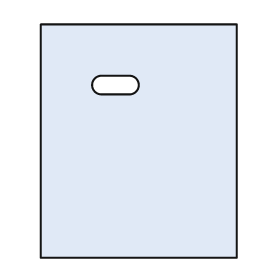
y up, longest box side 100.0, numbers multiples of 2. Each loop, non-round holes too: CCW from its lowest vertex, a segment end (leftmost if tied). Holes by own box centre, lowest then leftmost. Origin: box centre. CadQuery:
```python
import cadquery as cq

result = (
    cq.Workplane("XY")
    .moveTo(-42.0, -50.0)
    .lineTo(42.0, -50.0)
    .lineTo(42.0, 50.0)
    .lineTo(-42.0, 50.0)
    .close()
    .moveTo(-16.0, 20.0)
    .lineTo(-4.0, 20.0)
    .threePointArc((0.0, 24.0), (-4.0, 28.0))
    .lineTo(-16.0, 28.0)
    .threePointArc((-20.0, 24.0), (-16.0, 20.0))
    .close()
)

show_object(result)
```